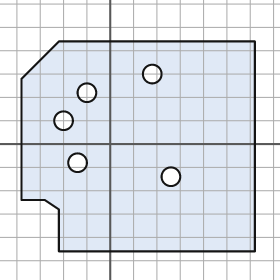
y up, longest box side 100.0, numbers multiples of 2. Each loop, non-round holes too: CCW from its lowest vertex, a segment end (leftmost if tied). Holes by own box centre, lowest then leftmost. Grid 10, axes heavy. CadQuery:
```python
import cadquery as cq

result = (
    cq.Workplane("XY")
    .moveTo(-22.0, -46.0)
    .lineTo(62.0, -46.0)
    .lineTo(62.0, 44.0)
    .lineTo(-22.0, 44.0)
    .lineTo(-38.0, 28.0)
    .lineTo(-38.0, -24.0)
    .lineTo(-28.0, -24.0)
    .lineTo(-22.0, -28.0)
    .close()
    .moveTo(26.0, -14.0)
    .circle(4.0)
    .moveTo(-14.0, -8.0)
    .circle(4.0)
    .moveTo(-20.0, 10.0)
    .circle(4.0)
    .moveTo(-10.0, 22.0)
    .circle(4.0)
    .moveTo(18.0, 30.0)
    .circle(4.0)
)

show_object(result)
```